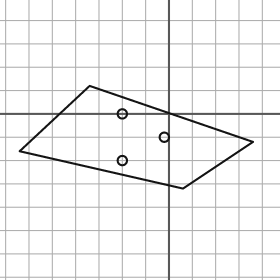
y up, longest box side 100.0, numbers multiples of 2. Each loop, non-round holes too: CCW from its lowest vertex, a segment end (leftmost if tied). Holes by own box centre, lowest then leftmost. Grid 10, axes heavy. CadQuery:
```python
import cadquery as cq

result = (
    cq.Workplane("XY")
    .moveTo(6.0, -32.0)
    .lineTo(36.0, -12.0)
    .lineTo(-34.0, 12.0)
    .lineTo(-64.0, -16.0)
    .close()
    .moveTo(-20.0, -20.0)
    .circle(2.0)
    .moveTo(-2.0, -10.0)
    .circle(2.0)
    .moveTo(-20.0, 0.0)
    .circle(2.0)
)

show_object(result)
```